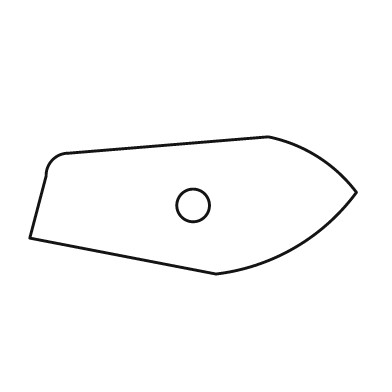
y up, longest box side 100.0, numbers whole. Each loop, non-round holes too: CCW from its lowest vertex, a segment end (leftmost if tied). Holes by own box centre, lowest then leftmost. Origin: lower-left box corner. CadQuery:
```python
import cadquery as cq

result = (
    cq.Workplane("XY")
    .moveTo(57.0, 0.0)
    .threePointArc((81.0, 8.0), (100.0, 25.0))
    .threePointArc((88.0, 36.0), (73.0, 42.0))
    .lineTo(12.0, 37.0)
    .threePointArc((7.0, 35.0), (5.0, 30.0))
    .lineTo(0.0, 11.0)
    .close()
    .moveTo(50.0, 21.0)
    .circle(5.0)
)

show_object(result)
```